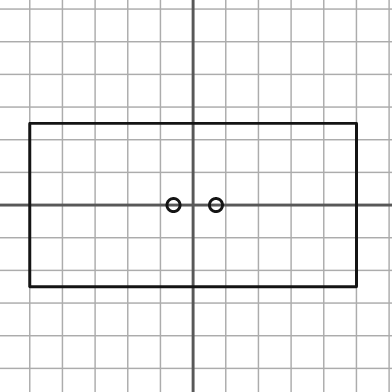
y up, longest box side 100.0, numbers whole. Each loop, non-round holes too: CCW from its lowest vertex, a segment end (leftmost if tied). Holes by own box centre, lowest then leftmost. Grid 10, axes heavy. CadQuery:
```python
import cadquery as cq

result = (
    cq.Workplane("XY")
    .moveTo(-50.0, -25.0)
    .lineTo(50.0, -25.0)
    .lineTo(50.0, 25.0)
    .lineTo(-50.0, 25.0)
    .close()
    .moveTo(-6.0, 0.0)
    .circle(2.0)
    .moveTo(7.0, 0.0)
    .circle(2.0)
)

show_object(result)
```